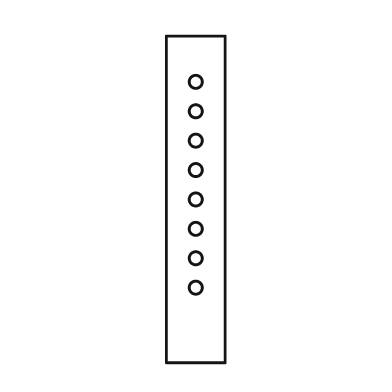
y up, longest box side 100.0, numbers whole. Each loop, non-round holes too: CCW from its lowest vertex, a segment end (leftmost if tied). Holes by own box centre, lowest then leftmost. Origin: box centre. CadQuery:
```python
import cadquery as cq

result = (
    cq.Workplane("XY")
    .moveTo(-9.0, -50.0)
    .lineTo(9.0, -50.0)
    .lineTo(9.0, 50.0)
    .lineTo(-9.0, 50.0)
    .close()
    .moveTo(0.0, -27.0)
    .circle(2.0)
    .moveTo(0.0, -18.0)
    .circle(2.0)
    .moveTo(0.0, -9.0)
    .circle(2.0)
    .moveTo(0.0, 0.0)
    .circle(2.0)
    .moveTo(0.0, 9.0)
    .circle(2.0)
    .moveTo(0.0, 18.0)
    .circle(2.0)
    .moveTo(0.0, 27.0)
    .circle(2.0)
    .moveTo(0.0, 36.0)
    .circle(2.0)
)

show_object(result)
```